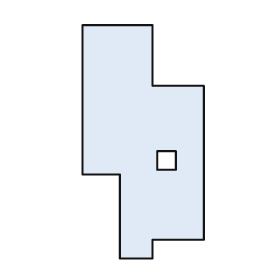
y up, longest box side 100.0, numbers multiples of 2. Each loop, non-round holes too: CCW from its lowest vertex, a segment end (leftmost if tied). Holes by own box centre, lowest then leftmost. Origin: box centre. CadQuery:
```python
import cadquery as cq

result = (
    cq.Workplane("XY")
    .moveTo(-10.0, -50.0)
    .lineTo(4.0, -50.0)
    .lineTo(4.0, -42.0)
    .lineTo(26.0, -42.0)
    .lineTo(26.0, 24.0)
    .lineTo(4.0, 24.0)
    .lineTo(4.0, 50.0)
    .lineTo(-26.0, 50.0)
    .lineTo(-26.0, -14.0)
    .lineTo(-10.0, -14.0)
    .close()
    .moveTo(6.0, -12.0)
    .lineTo(14.0, -12.0)
    .lineTo(14.0, -4.0)
    .lineTo(6.0, -4.0)
    .close()
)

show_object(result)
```